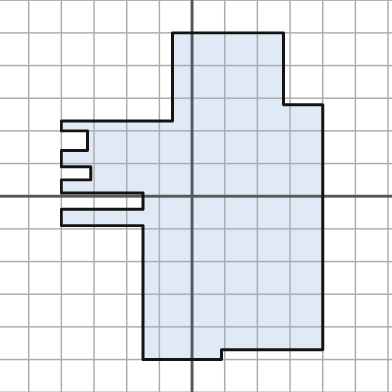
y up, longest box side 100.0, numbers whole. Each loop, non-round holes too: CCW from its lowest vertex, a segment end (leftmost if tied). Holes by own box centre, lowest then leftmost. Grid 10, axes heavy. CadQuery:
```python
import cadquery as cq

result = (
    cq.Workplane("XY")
    .moveTo(-15.0, -50.0)
    .lineTo(9.0, -50.0)
    .lineTo(9.0, -47.0)
    .lineTo(40.0, -47.0)
    .lineTo(40.0, 28.0)
    .lineTo(28.0, 28.0)
    .lineTo(28.0, 50.0)
    .lineTo(-6.0, 50.0)
    .lineTo(-6.0, 23.0)
    .lineTo(-40.0, 23.0)
    .lineTo(-40.0, 20.0)
    .lineTo(-32.0, 20.0)
    .lineTo(-32.0, 14.0)
    .lineTo(-40.0, 14.0)
    .lineTo(-40.0, 9.0)
    .lineTo(-31.0, 9.0)
    .lineTo(-31.0, 5.0)
    .lineTo(-40.0, 5.0)
    .lineTo(-40.0, 1.0)
    .lineTo(-15.0, 1.0)
    .lineTo(-15.0, -4.0)
    .lineTo(-40.0, -4.0)
    .lineTo(-40.0, -9.0)
    .lineTo(-15.0, -9.0)
    .close()
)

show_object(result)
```